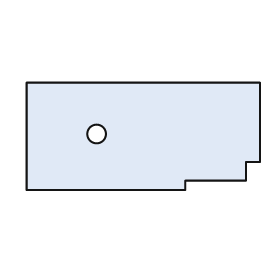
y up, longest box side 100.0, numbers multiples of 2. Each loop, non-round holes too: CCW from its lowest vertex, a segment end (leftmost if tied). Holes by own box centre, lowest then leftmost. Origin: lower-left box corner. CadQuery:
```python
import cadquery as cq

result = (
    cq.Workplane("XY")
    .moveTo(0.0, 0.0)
    .lineTo(68.0, 0.0)
    .lineTo(68.0, 4.0)
    .lineTo(94.0, 4.0)
    .lineTo(94.0, 12.0)
    .lineTo(100.0, 12.0)
    .lineTo(100.0, 46.0)
    .lineTo(0.0, 46.0)
    .close()
    .moveTo(30.0, 24.0)
    .circle(4.0)
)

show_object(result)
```